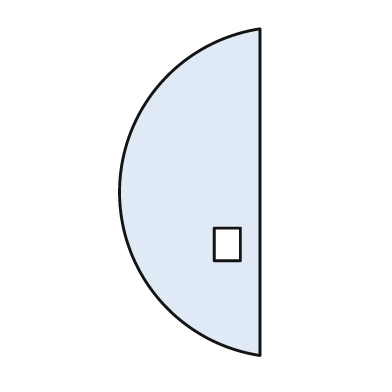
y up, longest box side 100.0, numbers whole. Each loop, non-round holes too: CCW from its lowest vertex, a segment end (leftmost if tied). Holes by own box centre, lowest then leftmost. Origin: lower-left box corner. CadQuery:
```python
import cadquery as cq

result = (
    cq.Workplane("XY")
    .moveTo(43.0, 0.0)
    .lineTo(43.0, 100.0)
    .threePointArc((0.0, 50.0), (43.0, 0.0))
    .close()
    .moveTo(29.0, 29.0)
    .lineTo(37.0, 29.0)
    .lineTo(37.0, 39.0)
    .lineTo(29.0, 39.0)
    .close()
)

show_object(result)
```